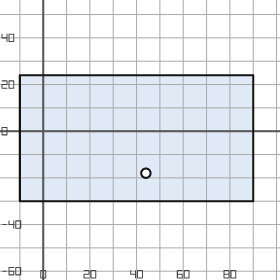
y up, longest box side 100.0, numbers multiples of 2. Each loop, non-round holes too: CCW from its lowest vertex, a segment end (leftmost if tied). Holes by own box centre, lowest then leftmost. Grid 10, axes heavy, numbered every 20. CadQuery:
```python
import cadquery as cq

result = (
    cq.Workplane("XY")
    .moveTo(-10.0, -30.0)
    .lineTo(90.0, -30.0)
    .lineTo(90.0, 24.0)
    .lineTo(-10.0, 24.0)
    .close()
    .moveTo(44.0, -18.0)
    .circle(2.0)
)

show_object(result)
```